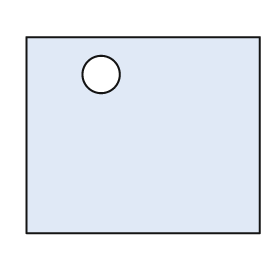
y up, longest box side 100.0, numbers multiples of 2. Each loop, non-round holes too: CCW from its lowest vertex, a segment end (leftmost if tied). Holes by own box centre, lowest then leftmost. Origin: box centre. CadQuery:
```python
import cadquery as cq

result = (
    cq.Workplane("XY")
    .moveTo(-50.0, -42.0)
    .lineTo(50.0, -42.0)
    .lineTo(50.0, 42.0)
    .lineTo(-50.0, 42.0)
    .close()
    .moveTo(-18.0, 26.0)
    .circle(8.0)
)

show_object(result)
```